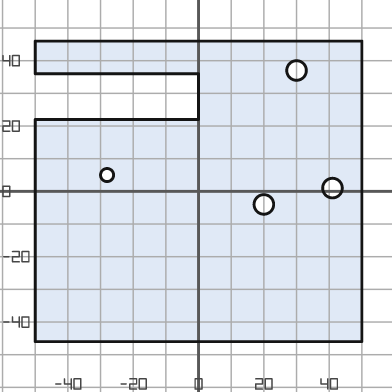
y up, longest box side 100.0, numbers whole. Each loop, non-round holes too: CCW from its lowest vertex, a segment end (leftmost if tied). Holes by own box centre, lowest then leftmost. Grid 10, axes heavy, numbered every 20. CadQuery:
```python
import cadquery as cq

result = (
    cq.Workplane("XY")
    .moveTo(-50.0, -46.0)
    .lineTo(50.0, -46.0)
    .lineTo(50.0, 46.0)
    .lineTo(-50.0, 46.0)
    .lineTo(-50.0, 36.0)
    .lineTo(0.0, 36.0)
    .lineTo(0.0, 22.0)
    .lineTo(-50.0, 22.0)
    .close()
    .moveTo(20.0, -4.0)
    .circle(3.0)
    .moveTo(41.0, 1.0)
    .circle(3.0)
    .moveTo(-28.0, 5.0)
    .circle(2.0)
    .moveTo(30.0, 37.0)
    .circle(3.0)
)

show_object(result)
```